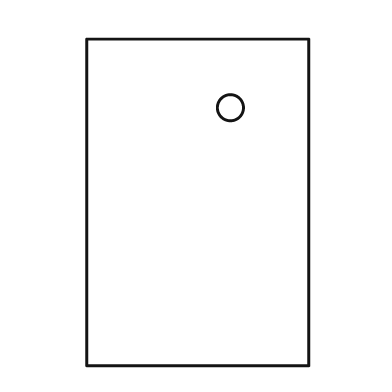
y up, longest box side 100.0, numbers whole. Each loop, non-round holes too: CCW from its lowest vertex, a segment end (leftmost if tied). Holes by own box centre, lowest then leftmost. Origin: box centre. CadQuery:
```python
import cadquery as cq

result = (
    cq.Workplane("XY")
    .moveTo(-34.0, -50.0)
    .lineTo(34.0, -50.0)
    .lineTo(34.0, 50.0)
    .lineTo(-34.0, 50.0)
    .close()
    .moveTo(10.0, 29.0)
    .circle(4.0)
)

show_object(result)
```